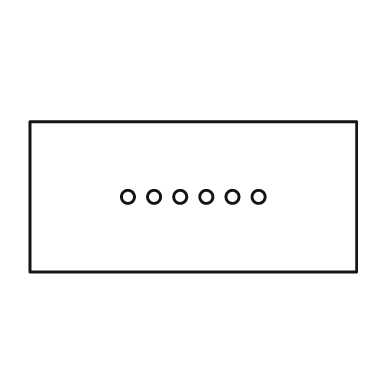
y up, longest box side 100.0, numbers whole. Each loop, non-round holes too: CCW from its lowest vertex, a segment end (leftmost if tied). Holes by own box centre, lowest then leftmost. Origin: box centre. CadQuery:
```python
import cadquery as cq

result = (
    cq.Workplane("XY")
    .moveTo(-50.0, -23.0)
    .lineTo(50.0, -23.0)
    .lineTo(50.0, 23.0)
    .lineTo(-50.0, 23.0)
    .close()
    .moveTo(-20.0, 0.0)
    .circle(2.0)
    .moveTo(-12.0, 0.0)
    .circle(2.0)
    .moveTo(-4.0, 0.0)
    .circle(2.0)
    .moveTo(4.0, 0.0)
    .circle(2.0)
    .moveTo(12.0, 0.0)
    .circle(2.0)
    .moveTo(20.0, 0.0)
    .circle(2.0)
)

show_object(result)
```